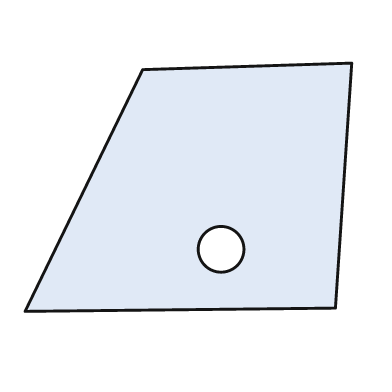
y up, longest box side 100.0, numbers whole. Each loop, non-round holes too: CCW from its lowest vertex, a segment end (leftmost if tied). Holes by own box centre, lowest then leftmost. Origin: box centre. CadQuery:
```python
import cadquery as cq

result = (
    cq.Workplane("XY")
    .moveTo(-50.0, -38.0)
    .lineTo(45.0, -37.0)
    .lineTo(50.0, 38.0)
    .lineTo(-14.0, 36.0)
    .close()
    .moveTo(10.0, -19.0)
    .circle(7.0)
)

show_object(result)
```